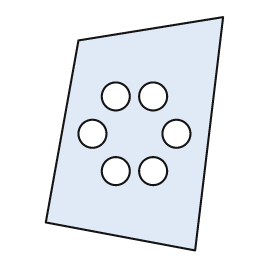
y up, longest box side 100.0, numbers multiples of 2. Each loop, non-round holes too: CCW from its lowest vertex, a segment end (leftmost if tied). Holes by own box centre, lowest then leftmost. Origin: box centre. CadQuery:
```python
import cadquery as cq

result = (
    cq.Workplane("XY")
    .moveTo(26.0, -50.0)
    .lineTo(38.0, 50.0)
    .lineTo(-24.0, 40.0)
    .lineTo(-38.0, -38.0)
    .close()
    .moveTo(-8.0, -16.0)
    .circle(6.0)
    .moveTo(8.0, -16.0)
    .circle(6.0)
    .moveTo(-18.0, 0.0)
    .circle(6.0)
    .moveTo(18.0, 0.0)
    .circle(6.0)
    .moveTo(-8.0, 16.0)
    .circle(6.0)
    .moveTo(8.0, 16.0)
    .circle(6.0)
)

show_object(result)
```